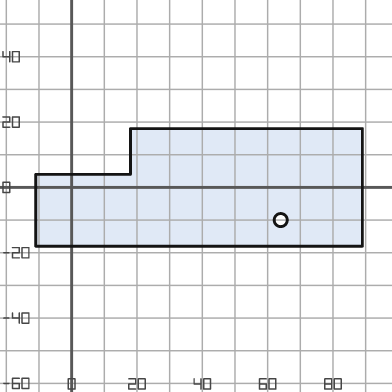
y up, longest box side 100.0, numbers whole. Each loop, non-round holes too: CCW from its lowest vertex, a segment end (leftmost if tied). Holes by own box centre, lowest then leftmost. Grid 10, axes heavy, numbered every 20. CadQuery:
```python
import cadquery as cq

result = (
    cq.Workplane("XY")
    .moveTo(-11.0, -18.0)
    .lineTo(89.0, -18.0)
    .lineTo(89.0, 18.0)
    .lineTo(18.0, 18.0)
    .lineTo(18.0, 4.0)
    .lineTo(-11.0, 4.0)
    .close()
    .moveTo(64.0, -10.0)
    .circle(2.0)
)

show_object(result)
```